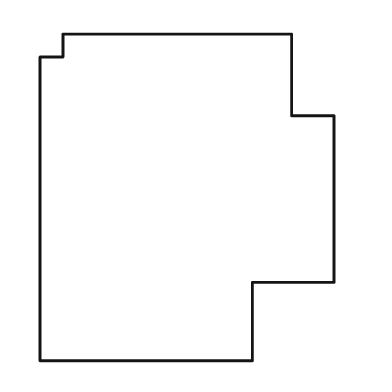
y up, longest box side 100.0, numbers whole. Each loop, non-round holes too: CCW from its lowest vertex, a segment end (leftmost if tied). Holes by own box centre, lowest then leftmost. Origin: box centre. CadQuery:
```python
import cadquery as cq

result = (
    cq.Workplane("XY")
    .moveTo(-45.0, -50.0)
    .lineTo(20.0, -50.0)
    .lineTo(20.0, -26.0)
    .lineTo(45.0, -26.0)
    .lineTo(45.0, 25.0)
    .lineTo(32.0, 25.0)
    .lineTo(32.0, 50.0)
    .lineTo(-38.0, 50.0)
    .lineTo(-38.0, 43.0)
    .lineTo(-45.0, 43.0)
    .close()
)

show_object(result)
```